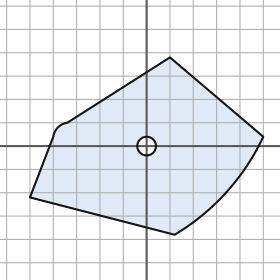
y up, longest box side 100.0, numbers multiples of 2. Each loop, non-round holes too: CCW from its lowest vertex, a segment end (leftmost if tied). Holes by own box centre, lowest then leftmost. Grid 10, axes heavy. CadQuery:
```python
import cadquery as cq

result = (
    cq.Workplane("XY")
    .moveTo(12.0, -38.0)
    .threePointArc((34.0, -20.0), (50.0, 4.0))
    .lineTo(10.0, 38.0)
    .lineTo(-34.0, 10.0)
    .threePointArc((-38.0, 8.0), (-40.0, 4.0))
    .lineTo(-50.0, -22.0)
    .close()
    .moveTo(0.0, 0.0)
    .circle(4.0)
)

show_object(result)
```